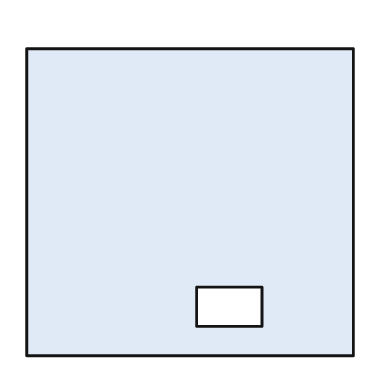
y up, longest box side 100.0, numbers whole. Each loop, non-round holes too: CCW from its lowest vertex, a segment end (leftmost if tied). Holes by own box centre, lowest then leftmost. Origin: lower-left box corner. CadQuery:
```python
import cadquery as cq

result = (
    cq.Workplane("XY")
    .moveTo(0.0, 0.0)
    .lineTo(100.0, 0.0)
    .lineTo(100.0, 94.0)
    .lineTo(0.0, 94.0)
    .close()
    .moveTo(52.0, 9.0)
    .lineTo(72.0, 9.0)
    .lineTo(72.0, 21.0)
    .lineTo(52.0, 21.0)
    .close()
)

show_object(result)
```